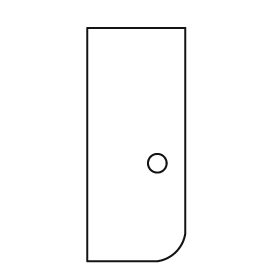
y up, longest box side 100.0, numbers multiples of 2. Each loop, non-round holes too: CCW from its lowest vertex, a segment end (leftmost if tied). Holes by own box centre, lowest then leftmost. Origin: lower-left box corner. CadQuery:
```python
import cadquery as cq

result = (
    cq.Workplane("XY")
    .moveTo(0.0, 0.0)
    .lineTo(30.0, 0.0)
    .threePointArc((38.0, 4.0), (42.0, 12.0))
    .lineTo(42.0, 100.0)
    .lineTo(0.0, 100.0)
    .close()
    .moveTo(30.0, 42.0)
    .circle(4.0)
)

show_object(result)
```